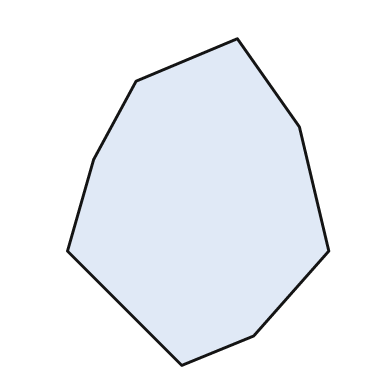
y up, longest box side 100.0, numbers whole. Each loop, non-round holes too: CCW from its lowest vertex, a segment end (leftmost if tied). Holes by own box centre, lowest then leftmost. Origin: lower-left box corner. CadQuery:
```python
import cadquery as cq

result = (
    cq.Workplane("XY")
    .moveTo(35.0, 0.0)
    .lineTo(57.0, 9.0)
    .lineTo(80.0, 35.0)
    .lineTo(71.0, 73.0)
    .lineTo(52.0, 100.0)
    .lineTo(21.0, 87.0)
    .lineTo(8.0, 63.0)
    .lineTo(0.0, 35.0)
    .close()
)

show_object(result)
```